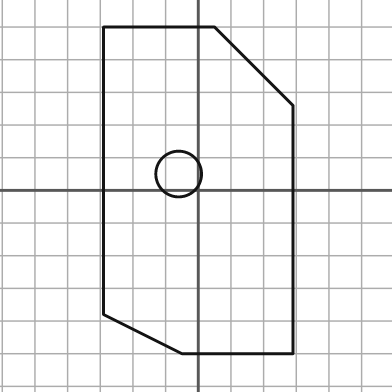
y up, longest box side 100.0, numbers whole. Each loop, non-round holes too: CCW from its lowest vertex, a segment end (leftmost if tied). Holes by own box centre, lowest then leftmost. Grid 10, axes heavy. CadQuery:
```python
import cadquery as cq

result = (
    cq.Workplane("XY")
    .moveTo(-5.0, -50.0)
    .lineTo(29.0, -50.0)
    .lineTo(29.0, 26.0)
    .lineTo(5.0, 50.0)
    .lineTo(-29.0, 50.0)
    .lineTo(-29.0, -38.0)
    .close()
    .moveTo(-6.0, 5.0)
    .circle(7.0)
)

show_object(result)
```